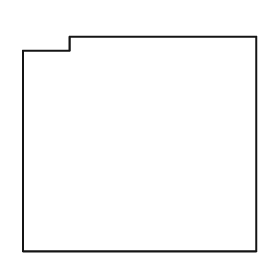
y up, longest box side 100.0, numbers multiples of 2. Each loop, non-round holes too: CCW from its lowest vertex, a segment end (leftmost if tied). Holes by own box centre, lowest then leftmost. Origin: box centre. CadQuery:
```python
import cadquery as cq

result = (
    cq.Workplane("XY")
    .moveTo(-50.0, -46.0)
    .lineTo(50.0, -46.0)
    .lineTo(50.0, 46.0)
    .lineTo(-30.0, 46.0)
    .lineTo(-30.0, 40.0)
    .lineTo(-50.0, 40.0)
    .close()
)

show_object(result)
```